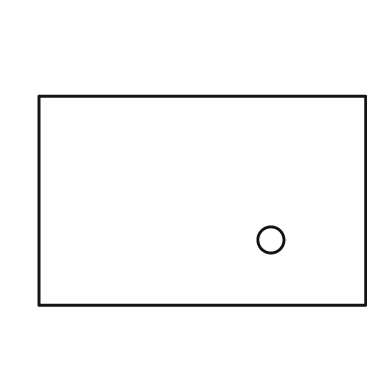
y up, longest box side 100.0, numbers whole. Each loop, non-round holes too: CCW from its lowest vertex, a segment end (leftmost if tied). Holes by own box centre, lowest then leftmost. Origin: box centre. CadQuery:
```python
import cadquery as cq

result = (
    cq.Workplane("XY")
    .moveTo(-50.0, -32.0)
    .lineTo(50.0, -32.0)
    .lineTo(50.0, 32.0)
    .lineTo(-50.0, 32.0)
    .close()
    .moveTo(21.0, -12.0)
    .circle(4.0)
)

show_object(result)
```